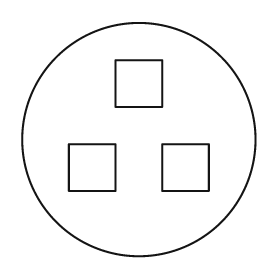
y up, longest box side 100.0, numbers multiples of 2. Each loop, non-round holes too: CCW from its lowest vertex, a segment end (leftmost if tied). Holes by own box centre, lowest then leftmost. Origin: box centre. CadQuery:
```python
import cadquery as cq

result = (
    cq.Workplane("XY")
    .moveTo(0.0, 0.0)
    .circle(50.0)
    .moveTo(-30.0, -22.0)
    .lineTo(-10.0, -22.0)
    .lineTo(-10.0, -2.0)
    .lineTo(-30.0, -2.0)
    .close()
    .moveTo(10.0, -22.0)
    .lineTo(30.0, -22.0)
    .lineTo(30.0, -2.0)
    .lineTo(10.0, -2.0)
    .close()
    .moveTo(-10.0, 14.0)
    .lineTo(10.0, 14.0)
    .lineTo(10.0, 34.0)
    .lineTo(-10.0, 34.0)
    .close()
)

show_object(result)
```